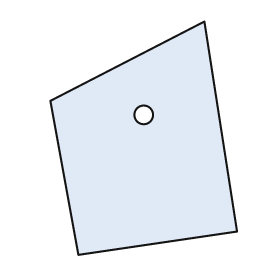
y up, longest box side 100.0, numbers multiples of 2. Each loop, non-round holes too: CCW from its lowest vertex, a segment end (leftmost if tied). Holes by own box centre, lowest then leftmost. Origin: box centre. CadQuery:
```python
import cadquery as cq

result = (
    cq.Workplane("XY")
    .moveTo(-28.0, -50.0)
    .lineTo(40.0, -40.0)
    .lineTo(26.0, 50.0)
    .lineTo(-40.0, 16.0)
    .close()
    .moveTo(0.0, 10.0)
    .circle(4.0)
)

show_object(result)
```